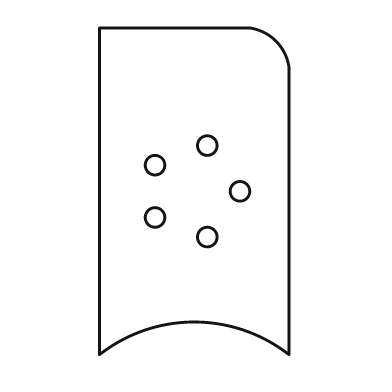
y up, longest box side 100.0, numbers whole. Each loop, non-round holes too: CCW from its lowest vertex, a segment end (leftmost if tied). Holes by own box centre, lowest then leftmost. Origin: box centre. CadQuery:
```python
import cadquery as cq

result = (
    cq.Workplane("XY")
    .moveTo(-29.0, -50.0)
    .threePointArc((0.0, -40.0), (29.0, -50.0))
    .lineTo(29.0, 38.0)
    .threePointArc((25.0, 46.0), (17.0, 50.0))
    .lineTo(-29.0, 50.0)
    .close()
    .moveTo(4.0, -14.0)
    .circle(3.0)
    .moveTo(-12.0, -8.0)
    .circle(3.0)
    .moveTo(14.0, 0.0)
    .circle(3.0)
    .moveTo(-12.0, 8.0)
    .circle(3.0)
    .moveTo(4.0, 14.0)
    .circle(3.0)
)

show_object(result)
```